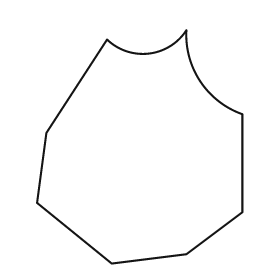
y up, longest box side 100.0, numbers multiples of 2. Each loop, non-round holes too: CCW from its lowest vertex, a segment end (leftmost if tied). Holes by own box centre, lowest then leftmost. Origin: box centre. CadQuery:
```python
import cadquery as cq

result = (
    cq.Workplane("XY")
    .moveTo(-12.0, -50.0)
    .lineTo(20.0, -46.0)
    .lineTo(44.0, -28.0)
    .lineTo(44.0, 14.0)
    .threePointArc((26.0, 28.0), (20.0, 50.0))
    .threePointArc((4.0, 40.0), (-14.0, 46.0))
    .lineTo(-40.0, 6.0)
    .lineTo(-44.0, -24.0)
    .close()
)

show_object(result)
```